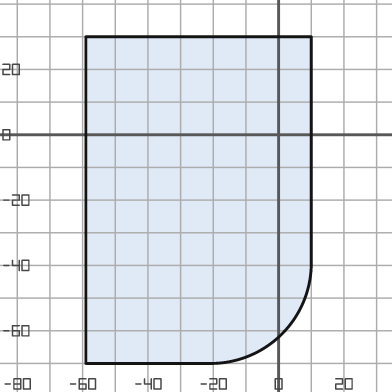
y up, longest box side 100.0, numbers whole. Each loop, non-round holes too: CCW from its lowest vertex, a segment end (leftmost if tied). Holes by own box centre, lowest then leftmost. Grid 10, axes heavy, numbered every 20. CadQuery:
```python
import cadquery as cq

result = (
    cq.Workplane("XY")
    .moveTo(-59.0, -70.0)
    .lineTo(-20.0, -70.0)
    .threePointArc((1.0, -61.0), (10.0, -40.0))
    .lineTo(10.0, 30.0)
    .lineTo(-59.0, 30.0)
    .close()
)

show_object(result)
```